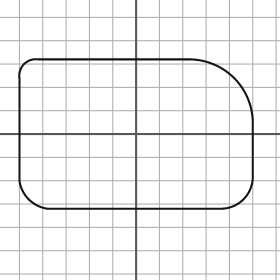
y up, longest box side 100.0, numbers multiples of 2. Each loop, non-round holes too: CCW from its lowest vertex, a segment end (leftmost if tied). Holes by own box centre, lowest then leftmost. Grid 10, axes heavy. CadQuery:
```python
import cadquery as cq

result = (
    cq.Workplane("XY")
    .moveTo(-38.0, -32.0)
    .lineTo(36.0, -32.0)
    .threePointArc((46.0, -28.0), (50.0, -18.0))
    .lineTo(50.0, 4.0)
    .threePointArc((42.0, 24.0), (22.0, 32.0))
    .lineTo(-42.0, 32.0)
    .threePointArc((-48.0, 30.0), (-50.0, 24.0))
    .lineTo(-50.0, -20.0)
    .threePointArc((-46.0, -28.0), (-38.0, -32.0))
    .close()
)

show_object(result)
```